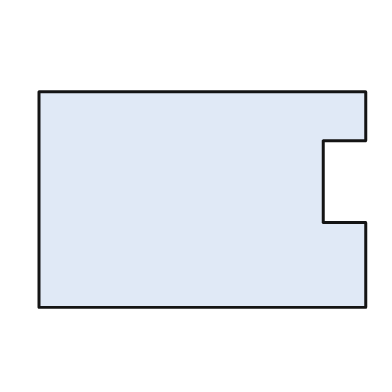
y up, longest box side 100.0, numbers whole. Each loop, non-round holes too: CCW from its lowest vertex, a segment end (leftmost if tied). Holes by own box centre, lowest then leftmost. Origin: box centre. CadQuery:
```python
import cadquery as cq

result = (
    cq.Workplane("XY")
    .moveTo(-50.0, -33.0)
    .lineTo(50.0, -33.0)
    .lineTo(50.0, -7.0)
    .lineTo(37.0, -7.0)
    .lineTo(37.0, 18.0)
    .lineTo(50.0, 18.0)
    .lineTo(50.0, 33.0)
    .lineTo(-50.0, 33.0)
    .close()
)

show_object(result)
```